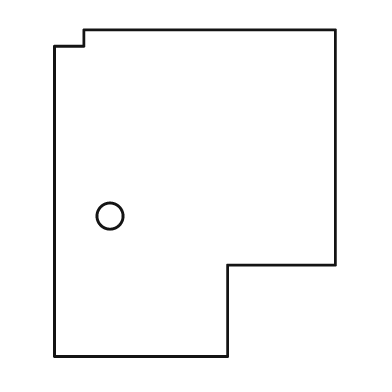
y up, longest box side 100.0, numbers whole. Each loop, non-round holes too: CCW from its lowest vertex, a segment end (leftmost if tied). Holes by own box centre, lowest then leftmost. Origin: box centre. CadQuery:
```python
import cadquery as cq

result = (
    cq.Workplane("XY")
    .moveTo(-43.0, -50.0)
    .lineTo(10.0, -50.0)
    .lineTo(10.0, -22.0)
    .lineTo(43.0, -22.0)
    .lineTo(43.0, 50.0)
    .lineTo(-34.0, 50.0)
    .lineTo(-34.0, 45.0)
    .lineTo(-43.0, 45.0)
    .close()
    .moveTo(-26.0, -7.0)
    .circle(4.0)
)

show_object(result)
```